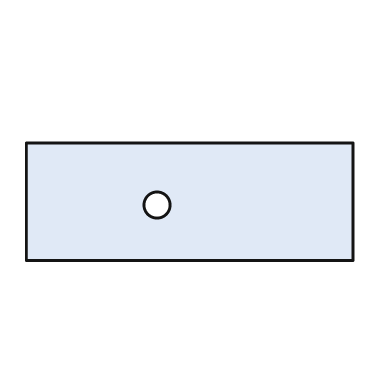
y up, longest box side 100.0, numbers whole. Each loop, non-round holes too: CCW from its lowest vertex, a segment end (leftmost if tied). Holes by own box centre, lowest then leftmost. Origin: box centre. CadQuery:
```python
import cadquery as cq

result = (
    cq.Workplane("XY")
    .moveTo(-50.0, -18.0)
    .lineTo(50.0, -18.0)
    .lineTo(50.0, 18.0)
    .lineTo(-50.0, 18.0)
    .close()
    .moveTo(-10.0, -1.0)
    .circle(4.0)
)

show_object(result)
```